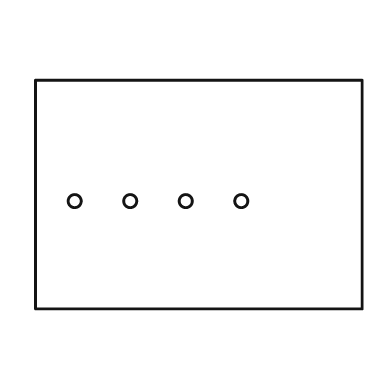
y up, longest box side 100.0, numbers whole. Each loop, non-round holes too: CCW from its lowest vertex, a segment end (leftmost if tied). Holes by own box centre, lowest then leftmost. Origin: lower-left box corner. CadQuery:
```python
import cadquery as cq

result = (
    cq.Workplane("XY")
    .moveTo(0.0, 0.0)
    .lineTo(100.0, 0.0)
    .lineTo(100.0, 70.0)
    .lineTo(0.0, 70.0)
    .close()
    .moveTo(12.0, 33.0)
    .circle(2.0)
    .moveTo(29.0, 33.0)
    .circle(2.0)
    .moveTo(46.0, 33.0)
    .circle(2.0)
    .moveTo(63.0, 33.0)
    .circle(2.0)
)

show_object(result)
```